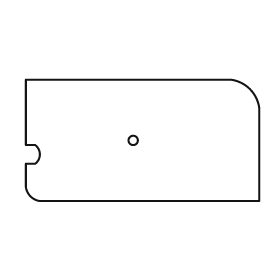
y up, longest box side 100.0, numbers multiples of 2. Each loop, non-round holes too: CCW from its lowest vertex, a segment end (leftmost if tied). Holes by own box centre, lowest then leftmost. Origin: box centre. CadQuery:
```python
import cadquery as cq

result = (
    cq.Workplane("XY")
    .moveTo(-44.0, -26.0)
    .lineTo(50.0, -26.0)
    .lineTo(50.0, 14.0)
    .threePointArc((46.0, 22.0), (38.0, 26.0))
    .lineTo(-50.0, 26.0)
    .lineTo(-50.0, -2.0)
    .lineTo(-46.0, -2.0)
    .threePointArc((-44.0, -6.0), (-46.0, -10.0))
    .lineTo(-50.0, -10.0)
    .lineTo(-50.0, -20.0)
    .threePointArc((-48.0, -24.0), (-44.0, -26.0))
    .close()
    .moveTo(-4.0, 0.0)
    .circle(2.0)
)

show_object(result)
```